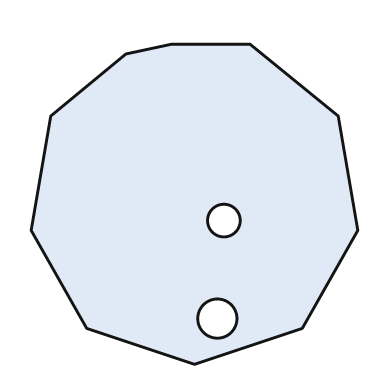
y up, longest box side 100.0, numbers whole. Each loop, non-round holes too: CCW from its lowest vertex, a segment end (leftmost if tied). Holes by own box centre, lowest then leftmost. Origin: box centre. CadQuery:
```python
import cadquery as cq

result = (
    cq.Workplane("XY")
    .moveTo(0.0, -49.0)
    .lineTo(33.0, -38.0)
    .lineTo(50.0, -8.0)
    .lineTo(44.0, 27.0)
    .lineTo(17.0, 49.0)
    .lineTo(-7.0, 49.0)
    .lineTo(-21.0, 46.0)
    .lineTo(-44.0, 27.0)
    .lineTo(-50.0, -8.0)
    .lineTo(-33.0, -38.0)
    .close()
    .moveTo(7.0, -35.0)
    .circle(6.0)
    .moveTo(9.0, -5.0)
    .circle(5.0)
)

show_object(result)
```